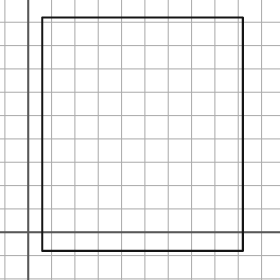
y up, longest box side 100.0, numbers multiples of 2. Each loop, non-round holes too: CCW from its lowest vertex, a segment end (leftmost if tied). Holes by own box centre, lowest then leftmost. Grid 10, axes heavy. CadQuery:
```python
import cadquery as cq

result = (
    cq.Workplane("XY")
    .moveTo(6.0, -8.0)
    .lineTo(92.0, -8.0)
    .lineTo(92.0, 92.0)
    .lineTo(6.0, 92.0)
    .close()
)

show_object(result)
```